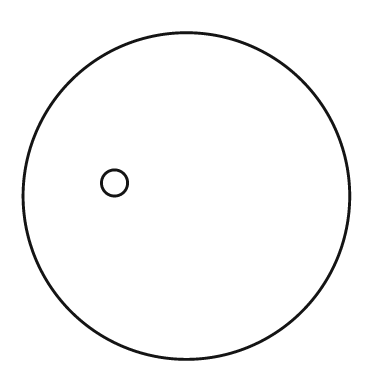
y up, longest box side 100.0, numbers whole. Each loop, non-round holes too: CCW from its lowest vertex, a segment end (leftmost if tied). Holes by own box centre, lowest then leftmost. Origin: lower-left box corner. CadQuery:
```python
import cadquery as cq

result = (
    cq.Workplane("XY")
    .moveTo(50.0, 50.0)
    .circle(50.0)
    .moveTo(28.0, 54.0)
    .circle(4.0)
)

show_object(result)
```